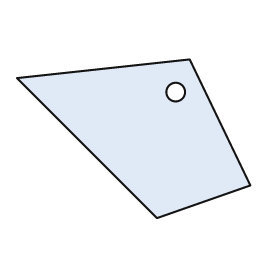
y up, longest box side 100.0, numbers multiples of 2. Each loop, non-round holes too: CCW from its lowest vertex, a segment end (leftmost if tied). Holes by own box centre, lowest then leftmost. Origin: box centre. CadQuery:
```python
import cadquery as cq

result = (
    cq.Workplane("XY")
    .moveTo(10.0, -34.0)
    .lineTo(50.0, -20.0)
    .lineTo(24.0, 34.0)
    .lineTo(-50.0, 26.0)
    .close()
    .moveTo(18.0, 20.0)
    .circle(4.0)
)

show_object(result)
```